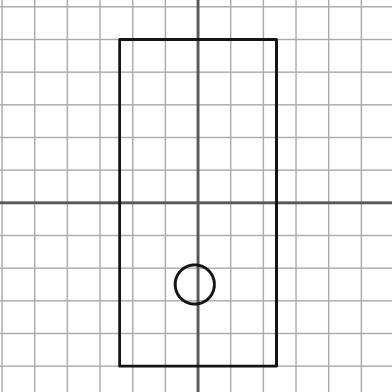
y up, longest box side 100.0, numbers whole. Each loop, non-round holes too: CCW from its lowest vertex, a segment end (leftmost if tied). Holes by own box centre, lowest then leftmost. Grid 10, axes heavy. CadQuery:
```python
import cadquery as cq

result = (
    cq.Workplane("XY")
    .moveTo(-24.0, -50.0)
    .lineTo(24.0, -50.0)
    .lineTo(24.0, 50.0)
    .lineTo(-24.0, 50.0)
    .close()
    .moveTo(-1.0, -25.0)
    .circle(6.0)
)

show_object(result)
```